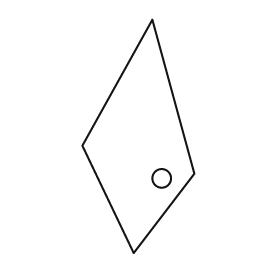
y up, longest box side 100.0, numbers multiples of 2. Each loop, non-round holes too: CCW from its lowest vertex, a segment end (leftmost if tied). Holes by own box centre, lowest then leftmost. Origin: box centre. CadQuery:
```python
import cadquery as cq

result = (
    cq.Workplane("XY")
    .moveTo(-2.0, -50.0)
    .lineTo(24.0, -16.0)
    .lineTo(6.0, 50.0)
    .lineTo(-24.0, -4.0)
    .close()
    .moveTo(10.0, -18.0)
    .circle(4.0)
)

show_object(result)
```